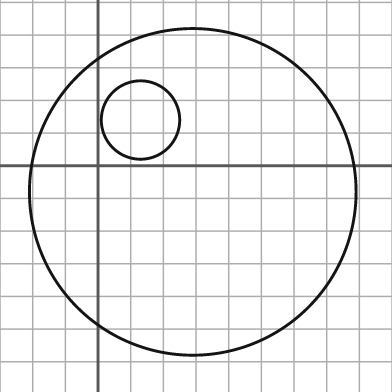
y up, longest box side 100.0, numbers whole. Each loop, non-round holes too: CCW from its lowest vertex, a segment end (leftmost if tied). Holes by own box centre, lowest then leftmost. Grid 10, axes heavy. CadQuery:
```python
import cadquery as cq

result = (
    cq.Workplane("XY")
    .moveTo(29.0, -8.0)
    .circle(50.0)
    .moveTo(13.0, 14.0)
    .circle(12.0)
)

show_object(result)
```